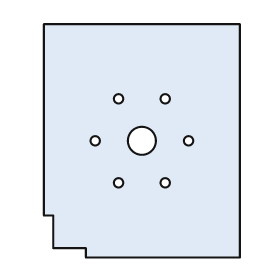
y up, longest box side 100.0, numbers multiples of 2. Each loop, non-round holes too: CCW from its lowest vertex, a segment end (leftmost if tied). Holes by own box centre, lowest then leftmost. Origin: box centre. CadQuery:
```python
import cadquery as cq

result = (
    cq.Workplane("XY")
    .moveTo(-24.0, -50.0)
    .lineTo(42.0, -50.0)
    .lineTo(42.0, 50.0)
    .lineTo(-42.0, 50.0)
    .lineTo(-42.0, -32.0)
    .lineTo(-38.0, -32.0)
    .lineTo(-38.0, -46.0)
    .lineTo(-24.0, -46.0)
    .close()
    .moveTo(-10.0, -18.0)
    .circle(2.0)
    .moveTo(10.0, -18.0)
    .circle(2.0)
    .moveTo(-20.0, 0.0)
    .circle(2.0)
    .moveTo(0.0, 0.0)
    .circle(6.0)
    .moveTo(20.0, 0.0)
    .circle(2.0)
    .moveTo(-10.0, 18.0)
    .circle(2.0)
    .moveTo(10.0, 18.0)
    .circle(2.0)
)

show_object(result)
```